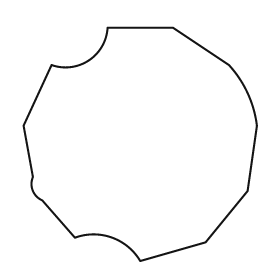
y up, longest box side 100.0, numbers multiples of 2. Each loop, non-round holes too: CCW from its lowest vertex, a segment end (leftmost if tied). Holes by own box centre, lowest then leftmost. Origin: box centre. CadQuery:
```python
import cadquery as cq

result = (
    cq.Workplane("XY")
    .moveTo(0.0, -50.0)
    .lineTo(28.0, -42.0)
    .lineTo(46.0, -20.0)
    .lineTo(50.0, 8.0)
    .threePointArc((46.0, 22.0), (38.0, 34.0))
    .lineTo(14.0, 50.0)
    .lineTo(-14.0, 50.0)
    .threePointArc((-22.0, 36.0), (-38.0, 34.0))
    .lineTo(-50.0, 8.0)
    .lineTo(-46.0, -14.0)
    .threePointArc((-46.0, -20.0), (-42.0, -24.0))
    .lineTo(-28.0, -40.0)
    .threePointArc((-12.0, -40.0), (0.0, -50.0))
    .close()
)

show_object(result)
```